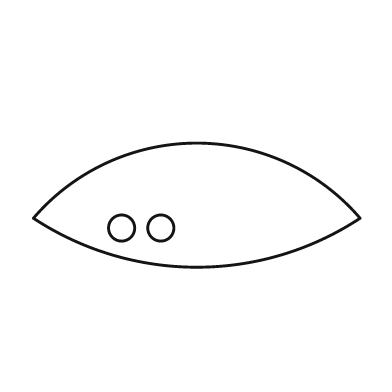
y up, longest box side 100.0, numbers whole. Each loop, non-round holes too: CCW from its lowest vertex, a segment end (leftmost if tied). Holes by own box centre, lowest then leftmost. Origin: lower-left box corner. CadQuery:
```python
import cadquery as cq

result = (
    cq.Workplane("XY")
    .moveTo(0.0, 15.0)
    .threePointArc((50.0, 0.0), (100.0, 15.0))
    .threePointArc((50.0, 38.0), (0.0, 15.0))
    .close()
    .moveTo(27.0, 12.0)
    .circle(4.0)
    .moveTo(39.0, 12.0)
    .circle(4.0)
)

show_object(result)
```